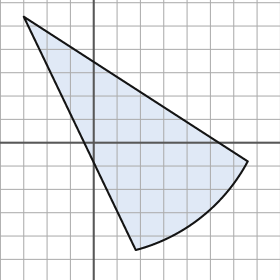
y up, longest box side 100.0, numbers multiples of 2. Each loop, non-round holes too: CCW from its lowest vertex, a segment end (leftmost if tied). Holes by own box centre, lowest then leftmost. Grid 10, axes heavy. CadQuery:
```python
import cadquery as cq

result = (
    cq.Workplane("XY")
    .moveTo(18.0, -46.0)
    .threePointArc((46.0, -32.0), (66.0, -8.0))
    .lineTo(-30.0, 54.0)
    .close()
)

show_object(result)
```